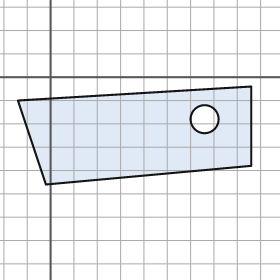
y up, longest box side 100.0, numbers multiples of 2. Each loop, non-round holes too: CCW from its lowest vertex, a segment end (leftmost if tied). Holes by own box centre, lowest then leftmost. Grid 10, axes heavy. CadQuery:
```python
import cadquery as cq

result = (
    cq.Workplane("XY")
    .moveTo(-2.0, -46.0)
    .lineTo(86.0, -38.0)
    .lineTo(86.0, -4.0)
    .lineTo(-14.0, -10.0)
    .close()
    .moveTo(66.0, -18.0)
    .circle(6.0)
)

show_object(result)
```